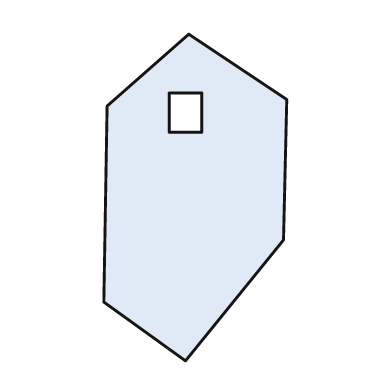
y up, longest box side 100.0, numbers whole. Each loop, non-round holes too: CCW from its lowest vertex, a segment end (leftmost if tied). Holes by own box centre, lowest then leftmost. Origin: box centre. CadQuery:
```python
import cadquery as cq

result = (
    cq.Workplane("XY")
    .moveTo(-3.0, -50.0)
    .lineTo(27.0, -13.0)
    .lineTo(28.0, 30.0)
    .lineTo(-2.0, 50.0)
    .lineTo(-27.0, 28.0)
    .lineTo(-28.0, -32.0)
    .close()
    .moveTo(-8.0, 20.0)
    .lineTo(2.0, 20.0)
    .lineTo(2.0, 32.0)
    .lineTo(-8.0, 32.0)
    .close()
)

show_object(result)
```